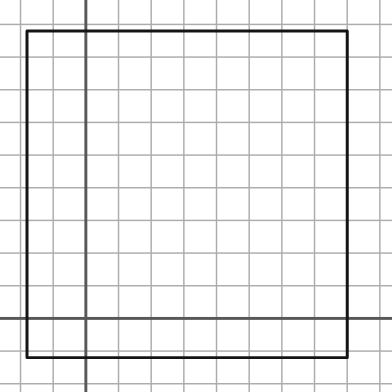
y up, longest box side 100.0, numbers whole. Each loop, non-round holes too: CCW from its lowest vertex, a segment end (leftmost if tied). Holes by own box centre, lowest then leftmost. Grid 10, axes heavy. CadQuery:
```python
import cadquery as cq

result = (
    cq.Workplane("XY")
    .moveTo(-18.0, -12.0)
    .lineTo(80.0, -12.0)
    .lineTo(80.0, 88.0)
    .lineTo(-18.0, 88.0)
    .close()
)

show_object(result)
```